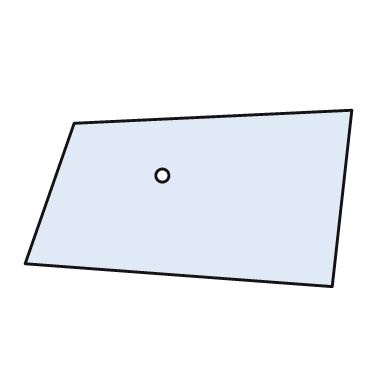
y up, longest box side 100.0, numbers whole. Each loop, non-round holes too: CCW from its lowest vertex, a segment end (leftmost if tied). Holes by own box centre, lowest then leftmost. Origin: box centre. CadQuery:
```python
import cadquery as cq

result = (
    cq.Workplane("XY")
    .moveTo(44.0, -27.0)
    .lineTo(50.0, 27.0)
    .lineTo(-35.0, 23.0)
    .lineTo(-50.0, -20.0)
    .close()
    .moveTo(-8.0, 7.0)
    .circle(2.0)
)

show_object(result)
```